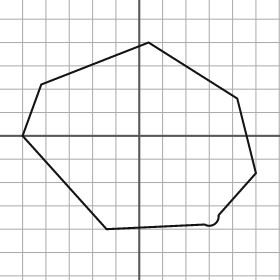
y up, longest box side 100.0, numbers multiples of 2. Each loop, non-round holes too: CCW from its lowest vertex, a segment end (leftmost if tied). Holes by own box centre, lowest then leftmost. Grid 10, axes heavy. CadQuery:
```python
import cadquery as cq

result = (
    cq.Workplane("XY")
    .moveTo(-14.0, -40.0)
    .lineTo(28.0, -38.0)
    .threePointArc((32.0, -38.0), (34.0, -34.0))
    .lineTo(50.0, -16.0)
    .lineTo(42.0, 16.0)
    .lineTo(4.0, 40.0)
    .lineTo(-42.0, 22.0)
    .lineTo(-50.0, 0.0)
    .close()
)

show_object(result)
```